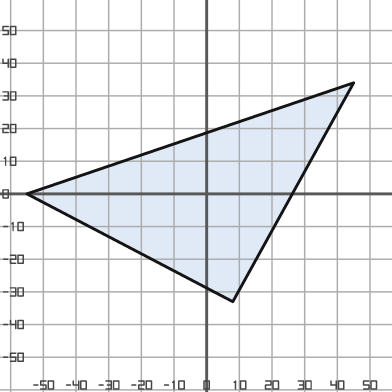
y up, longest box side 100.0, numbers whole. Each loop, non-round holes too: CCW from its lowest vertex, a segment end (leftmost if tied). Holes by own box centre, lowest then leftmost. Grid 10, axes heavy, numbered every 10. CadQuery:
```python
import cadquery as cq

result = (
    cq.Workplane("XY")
    .moveTo(8.0, -33.0)
    .lineTo(45.0, 34.0)
    .lineTo(-55.0, 0.0)
    .close()
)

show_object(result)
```